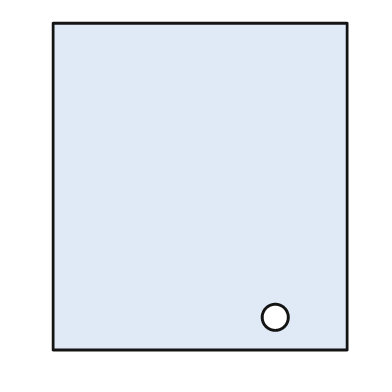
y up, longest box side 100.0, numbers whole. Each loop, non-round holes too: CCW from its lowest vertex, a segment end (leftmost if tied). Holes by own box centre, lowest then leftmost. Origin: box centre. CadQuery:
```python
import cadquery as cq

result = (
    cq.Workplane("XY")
    .moveTo(-45.0, -50.0)
    .lineTo(45.0, -50.0)
    .lineTo(45.0, 50.0)
    .lineTo(-45.0, 50.0)
    .close()
    .moveTo(23.0, -40.0)
    .circle(4.0)
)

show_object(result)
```